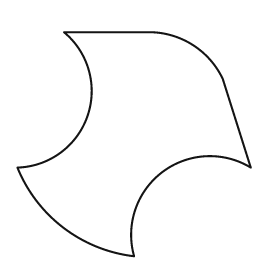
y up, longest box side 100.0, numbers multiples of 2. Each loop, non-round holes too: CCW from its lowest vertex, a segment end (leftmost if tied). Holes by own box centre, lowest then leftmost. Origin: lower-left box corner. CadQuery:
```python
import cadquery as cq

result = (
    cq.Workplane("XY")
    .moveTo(50.0, 0.0)
    .threePointArc((62.0, 36.0), (100.0, 38.0))
    .lineTo(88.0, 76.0)
    .threePointArc((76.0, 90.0), (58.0, 96.0))
    .lineTo(20.0, 96.0)
    .threePointArc((30.0, 60.0), (0.0, 38.0))
    .threePointArc((20.0, 12.0), (50.0, 0.0))
    .close()
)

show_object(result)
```